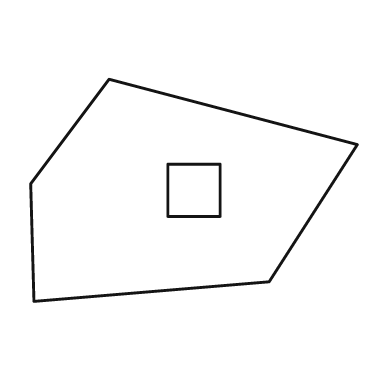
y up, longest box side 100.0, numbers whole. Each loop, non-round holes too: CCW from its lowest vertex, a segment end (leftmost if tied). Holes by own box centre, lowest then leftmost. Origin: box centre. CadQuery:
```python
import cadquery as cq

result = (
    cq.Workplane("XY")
    .moveTo(-49.0, -34.0)
    .lineTo(23.0, -28.0)
    .lineTo(50.0, 14.0)
    .lineTo(-26.0, 34.0)
    .lineTo(-50.0, 2.0)
    .close()
    .moveTo(-8.0, -8.0)
    .lineTo(8.0, -8.0)
    .lineTo(8.0, 8.0)
    .lineTo(-8.0, 8.0)
    .close()
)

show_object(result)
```